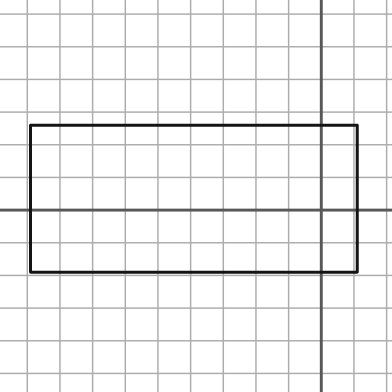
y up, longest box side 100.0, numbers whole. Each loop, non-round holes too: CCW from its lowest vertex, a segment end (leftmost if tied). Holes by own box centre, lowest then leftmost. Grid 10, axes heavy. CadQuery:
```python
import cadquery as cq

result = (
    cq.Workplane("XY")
    .moveTo(-89.0, -19.0)
    .lineTo(11.0, -19.0)
    .lineTo(11.0, 26.0)
    .lineTo(-89.0, 26.0)
    .close()
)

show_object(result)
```